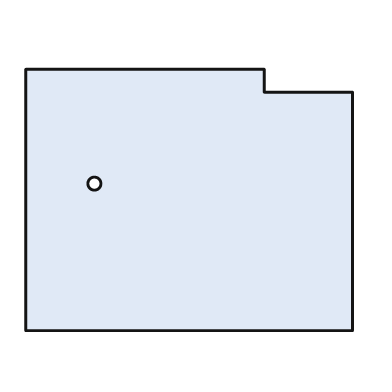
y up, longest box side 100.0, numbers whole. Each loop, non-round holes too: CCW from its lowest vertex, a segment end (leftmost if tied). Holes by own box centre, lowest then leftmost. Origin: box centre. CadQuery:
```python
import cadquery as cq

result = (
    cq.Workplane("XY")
    .moveTo(-50.0, -40.0)
    .lineTo(50.0, -40.0)
    .lineTo(50.0, 33.0)
    .lineTo(23.0, 33.0)
    .lineTo(23.0, 40.0)
    .lineTo(-50.0, 40.0)
    .close()
    .moveTo(-29.0, 5.0)
    .circle(2.0)
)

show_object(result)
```